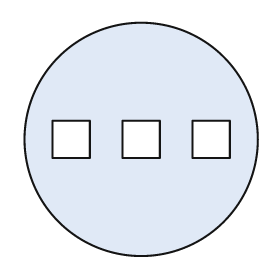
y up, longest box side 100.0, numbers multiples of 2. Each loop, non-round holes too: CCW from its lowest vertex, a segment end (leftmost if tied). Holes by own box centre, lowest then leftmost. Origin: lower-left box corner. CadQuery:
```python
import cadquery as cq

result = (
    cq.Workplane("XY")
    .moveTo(50.0, 50.0)
    .circle(50.0)
    .moveTo(12.0, 42.0)
    .lineTo(28.0, 42.0)
    .lineTo(28.0, 58.0)
    .lineTo(12.0, 58.0)
    .close()
    .moveTo(42.0, 42.0)
    .lineTo(58.0, 42.0)
    .lineTo(58.0, 58.0)
    .lineTo(42.0, 58.0)
    .close()
    .moveTo(72.0, 42.0)
    .lineTo(88.0, 42.0)
    .lineTo(88.0, 58.0)
    .lineTo(72.0, 58.0)
    .close()
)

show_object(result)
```